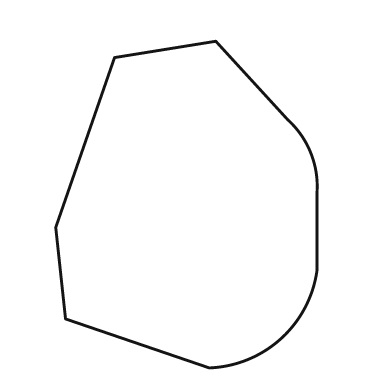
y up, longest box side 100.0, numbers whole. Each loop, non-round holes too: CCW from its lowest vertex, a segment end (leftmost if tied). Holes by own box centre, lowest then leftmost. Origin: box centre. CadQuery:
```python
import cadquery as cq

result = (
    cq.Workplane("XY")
    .moveTo(7.0, -50.0)
    .threePointArc((29.0, -41.0), (40.0, -20.0))
    .lineTo(40.0, 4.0)
    .threePointArc((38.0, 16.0), (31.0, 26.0))
    .lineTo(9.0, 50.0)
    .lineTo(-22.0, 45.0)
    .lineTo(-40.0, -7.0)
    .lineTo(-37.0, -35.0)
    .close()
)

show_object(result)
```